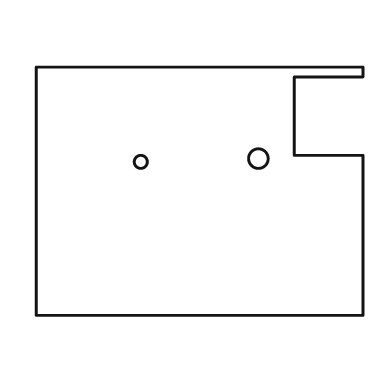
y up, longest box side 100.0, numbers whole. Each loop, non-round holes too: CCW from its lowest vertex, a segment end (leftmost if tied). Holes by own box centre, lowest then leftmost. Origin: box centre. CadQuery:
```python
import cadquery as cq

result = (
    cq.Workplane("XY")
    .moveTo(-50.0, -38.0)
    .lineTo(50.0, -38.0)
    .lineTo(50.0, 11.0)
    .lineTo(29.0, 11.0)
    .lineTo(29.0, 35.0)
    .lineTo(50.0, 35.0)
    .lineTo(50.0, 38.0)
    .lineTo(-50.0, 38.0)
    .close()
    .moveTo(-18.0, 9.0)
    .circle(2.0)
    .moveTo(18.0, 10.0)
    .circle(3.0)
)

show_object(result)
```